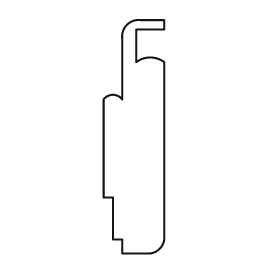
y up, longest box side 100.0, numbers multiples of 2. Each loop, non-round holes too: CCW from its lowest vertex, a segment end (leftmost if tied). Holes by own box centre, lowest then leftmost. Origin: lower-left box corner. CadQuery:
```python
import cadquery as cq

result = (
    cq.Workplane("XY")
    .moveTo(8.0, 0.0)
    .lineTo(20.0, 0.0)
    .threePointArc((24.0, 2.0), (26.0, 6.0))
    .lineTo(26.0, 82.0)
    .threePointArc((20.0, 84.0), (14.0, 82.0))
    .lineTo(14.0, 96.0)
    .lineTo(26.0, 96.0)
    .lineTo(26.0, 100.0)
    .lineTo(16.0, 100.0)
    .threePointArc((10.0, 98.0), (8.0, 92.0))
    .lineTo(8.0, 66.0)
    .threePointArc((4.0, 68.0), (0.0, 66.0))
    .lineTo(0.0, 24.0)
    .lineTo(4.0, 24.0)
    .lineTo(4.0, 6.0)
    .lineTo(8.0, 6.0)
    .close()
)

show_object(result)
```